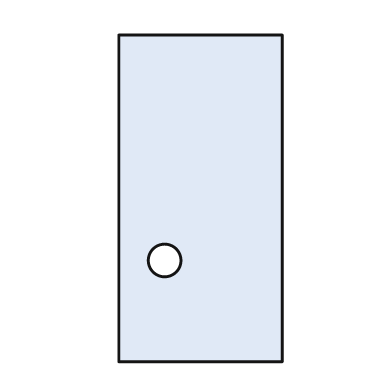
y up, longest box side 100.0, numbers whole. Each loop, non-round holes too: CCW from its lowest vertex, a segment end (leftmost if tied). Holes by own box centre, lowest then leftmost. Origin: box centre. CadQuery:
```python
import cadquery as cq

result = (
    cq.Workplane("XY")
    .moveTo(-25.0, -50.0)
    .lineTo(25.0, -50.0)
    .lineTo(25.0, 50.0)
    .lineTo(-25.0, 50.0)
    .close()
    .moveTo(-11.0, -19.0)
    .circle(5.0)
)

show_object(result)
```